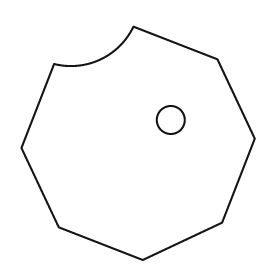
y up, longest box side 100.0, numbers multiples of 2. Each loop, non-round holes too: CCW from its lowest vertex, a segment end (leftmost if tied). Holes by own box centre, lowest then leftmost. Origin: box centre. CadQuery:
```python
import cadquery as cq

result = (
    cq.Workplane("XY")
    .moveTo(2.0, -50.0)
    .lineTo(36.0, -34.0)
    .lineTo(50.0, 2.0)
    .lineTo(34.0, 36.0)
    .lineTo(-2.0, 50.0)
    .threePointArc((-16.0, 36.0), (-36.0, 34.0))
    .lineTo(-50.0, -2.0)
    .lineTo(-34.0, -36.0)
    .close()
    .moveTo(14.0, 10.0)
    .circle(6.0)
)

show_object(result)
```